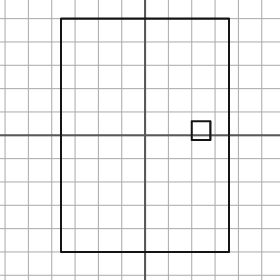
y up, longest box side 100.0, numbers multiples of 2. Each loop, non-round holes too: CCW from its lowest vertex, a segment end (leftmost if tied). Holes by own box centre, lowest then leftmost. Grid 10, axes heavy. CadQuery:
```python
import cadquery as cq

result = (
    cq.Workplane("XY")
    .moveTo(-36.0, -50.0)
    .lineTo(36.0, -50.0)
    .lineTo(36.0, 50.0)
    .lineTo(-36.0, 50.0)
    .close()
    .moveTo(20.0, -2.0)
    .lineTo(28.0, -2.0)
    .lineTo(28.0, 6.0)
    .lineTo(20.0, 6.0)
    .close()
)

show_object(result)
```